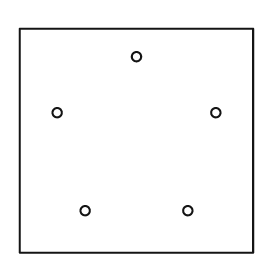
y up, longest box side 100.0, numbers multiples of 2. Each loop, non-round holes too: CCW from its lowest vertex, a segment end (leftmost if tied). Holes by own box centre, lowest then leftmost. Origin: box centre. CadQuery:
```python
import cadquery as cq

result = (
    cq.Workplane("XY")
    .moveTo(-50.0, -48.0)
    .lineTo(50.0, -48.0)
    .lineTo(50.0, 48.0)
    .lineTo(-50.0, 48.0)
    .close()
    .moveTo(-22.0, -30.0)
    .circle(2.0)
    .moveTo(22.0, -30.0)
    .circle(2.0)
    .moveTo(-34.0, 12.0)
    .circle(2.0)
    .moveTo(34.0, 12.0)
    .circle(2.0)
    .moveTo(0.0, 36.0)
    .circle(2.0)
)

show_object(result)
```